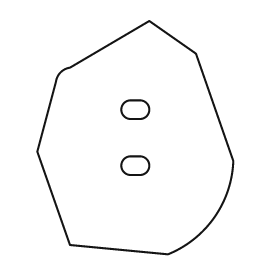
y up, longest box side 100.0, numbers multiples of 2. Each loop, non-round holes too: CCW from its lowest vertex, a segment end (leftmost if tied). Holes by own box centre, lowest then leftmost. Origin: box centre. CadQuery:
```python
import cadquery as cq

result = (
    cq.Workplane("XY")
    .moveTo(14.0, -50.0)
    .threePointArc((34.0, -34.0), (42.0, -10.0))
    .lineTo(26.0, 36.0)
    .lineTo(6.0, 50.0)
    .lineTo(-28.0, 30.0)
    .threePointArc((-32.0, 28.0), (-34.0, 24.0))
    .lineTo(-42.0, -6.0)
    .lineTo(-28.0, -46.0)
    .close()
    .moveTo(-2.0, -16.0)
    .lineTo(2.0, -16.0)
    .threePointArc((6.0, -12.0), (2.0, -8.0))
    .lineTo(-2.0, -8.0)
    .threePointArc((-6.0, -12.0), (-2.0, -16.0))
    .close()
    .moveTo(-2.0, 8.0)
    .lineTo(2.0, 8.0)
    .threePointArc((6.0, 12.0), (2.0, 16.0))
    .lineTo(-2.0, 16.0)
    .threePointArc((-6.0, 12.0), (-2.0, 8.0))
    .close()
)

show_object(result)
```